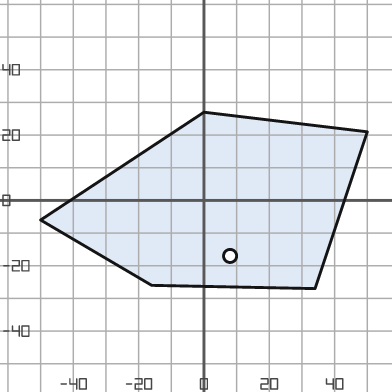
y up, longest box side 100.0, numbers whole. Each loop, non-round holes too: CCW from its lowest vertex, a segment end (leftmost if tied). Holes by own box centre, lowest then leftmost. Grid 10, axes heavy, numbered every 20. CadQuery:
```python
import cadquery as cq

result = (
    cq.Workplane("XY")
    .moveTo(34.0, -27.0)
    .lineTo(50.0, 21.0)
    .lineTo(0.0, 27.0)
    .lineTo(-50.0, -6.0)
    .lineTo(-16.0, -26.0)
    .close()
    .moveTo(8.0, -17.0)
    .circle(2.0)
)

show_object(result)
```